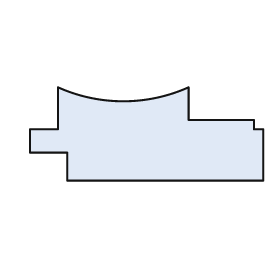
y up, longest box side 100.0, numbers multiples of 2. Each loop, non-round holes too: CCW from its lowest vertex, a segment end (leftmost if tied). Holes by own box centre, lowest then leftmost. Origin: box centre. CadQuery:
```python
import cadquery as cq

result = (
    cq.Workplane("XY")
    .moveTo(-34.0, -20.0)
    .lineTo(50.0, -20.0)
    .lineTo(50.0, 2.0)
    .lineTo(46.0, 2.0)
    .lineTo(46.0, 6.0)
    .lineTo(18.0, 6.0)
    .lineTo(18.0, 20.0)
    .threePointArc((-10.0, 14.0), (-38.0, 20.0))
    .lineTo(-38.0, 2.0)
    .lineTo(-50.0, 2.0)
    .lineTo(-50.0, -8.0)
    .lineTo(-34.0, -8.0)
    .close()
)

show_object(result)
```